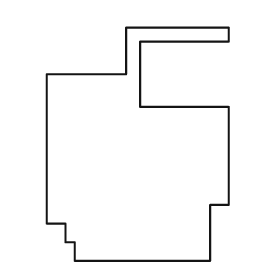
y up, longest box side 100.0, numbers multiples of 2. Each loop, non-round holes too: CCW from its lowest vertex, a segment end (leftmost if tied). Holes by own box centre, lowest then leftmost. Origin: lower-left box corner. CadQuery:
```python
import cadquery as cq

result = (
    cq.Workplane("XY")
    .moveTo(12.0, 0.0)
    .lineTo(70.0, 0.0)
    .lineTo(70.0, 24.0)
    .lineTo(78.0, 24.0)
    .lineTo(78.0, 66.0)
    .lineTo(40.0, 66.0)
    .lineTo(40.0, 94.0)
    .lineTo(78.0, 94.0)
    .lineTo(78.0, 100.0)
    .lineTo(34.0, 100.0)
    .lineTo(34.0, 80.0)
    .lineTo(0.0, 80.0)
    .lineTo(0.0, 16.0)
    .lineTo(8.0, 16.0)
    .lineTo(8.0, 8.0)
    .lineTo(12.0, 8.0)
    .close()
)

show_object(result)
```